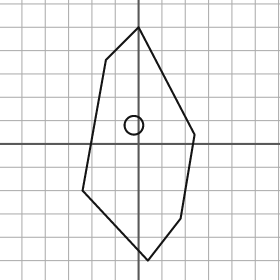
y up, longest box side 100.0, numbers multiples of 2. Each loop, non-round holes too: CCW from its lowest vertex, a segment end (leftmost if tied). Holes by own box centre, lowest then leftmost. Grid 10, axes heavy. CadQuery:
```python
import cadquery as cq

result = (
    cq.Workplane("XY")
    .moveTo(4.0, -50.0)
    .lineTo(18.0, -32.0)
    .lineTo(24.0, 4.0)
    .lineTo(0.0, 50.0)
    .lineTo(-14.0, 36.0)
    .lineTo(-24.0, -20.0)
    .close()
    .moveTo(-2.0, 8.0)
    .circle(4.0)
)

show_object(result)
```